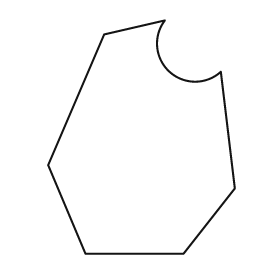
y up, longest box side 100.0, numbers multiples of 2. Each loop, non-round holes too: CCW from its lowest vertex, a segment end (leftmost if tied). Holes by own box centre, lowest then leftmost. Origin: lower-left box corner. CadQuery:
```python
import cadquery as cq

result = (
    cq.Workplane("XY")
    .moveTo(16.0, 0.0)
    .lineTo(58.0, 0.0)
    .lineTo(80.0, 28.0)
    .lineTo(74.0, 78.0)
    .threePointArc((52.0, 78.0), (50.0, 100.0))
    .lineTo(24.0, 94.0)
    .lineTo(0.0, 38.0)
    .close()
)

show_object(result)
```